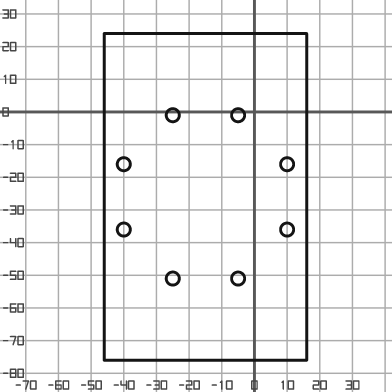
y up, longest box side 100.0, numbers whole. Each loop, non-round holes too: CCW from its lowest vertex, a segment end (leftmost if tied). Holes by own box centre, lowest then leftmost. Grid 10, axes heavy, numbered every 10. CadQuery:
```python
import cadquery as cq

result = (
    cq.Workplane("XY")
    .moveTo(-46.0, -76.0)
    .lineTo(16.0, -76.0)
    .lineTo(16.0, 24.0)
    .lineTo(-46.0, 24.0)
    .close()
    .moveTo(-25.0, -51.0)
    .circle(2.0)
    .moveTo(-5.0, -51.0)
    .circle(2.0)
    .moveTo(-40.0, -36.0)
    .circle(2.0)
    .moveTo(10.0, -36.0)
    .circle(2.0)
    .moveTo(-40.0, -16.0)
    .circle(2.0)
    .moveTo(10.0, -16.0)
    .circle(2.0)
    .moveTo(-25.0, -1.0)
    .circle(2.0)
    .moveTo(-5.0, -1.0)
    .circle(2.0)
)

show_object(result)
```